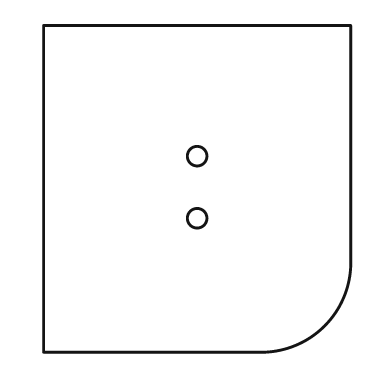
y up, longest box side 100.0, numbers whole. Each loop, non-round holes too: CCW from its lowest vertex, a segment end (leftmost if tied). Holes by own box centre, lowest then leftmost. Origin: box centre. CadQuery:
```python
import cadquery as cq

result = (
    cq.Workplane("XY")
    .moveTo(-47.0, -50.0)
    .lineTo(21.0, -50.0)
    .threePointArc((39.0, -42.0), (47.0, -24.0))
    .lineTo(47.0, 50.0)
    .lineTo(-47.0, 50.0)
    .close()
    .moveTo(0.0, -9.0)
    .circle(3.0)
    .moveTo(0.0, 10.0)
    .circle(3.0)
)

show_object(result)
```